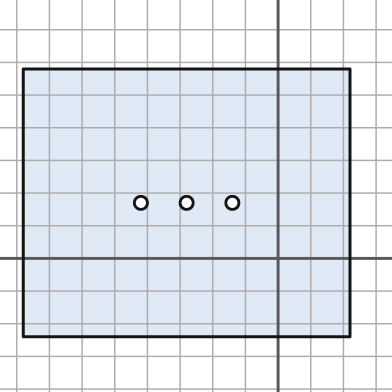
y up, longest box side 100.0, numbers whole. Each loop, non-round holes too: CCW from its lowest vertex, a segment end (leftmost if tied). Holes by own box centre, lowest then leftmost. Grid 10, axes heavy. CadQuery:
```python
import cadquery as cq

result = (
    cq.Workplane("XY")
    .moveTo(-78.0, -24.0)
    .lineTo(22.0, -24.0)
    .lineTo(22.0, 58.0)
    .lineTo(-78.0, 58.0)
    .close()
    .moveTo(-42.0, 17.0)
    .circle(2.0)
    .moveTo(-28.0, 17.0)
    .circle(2.0)
    .moveTo(-14.0, 17.0)
    .circle(2.0)
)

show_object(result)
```